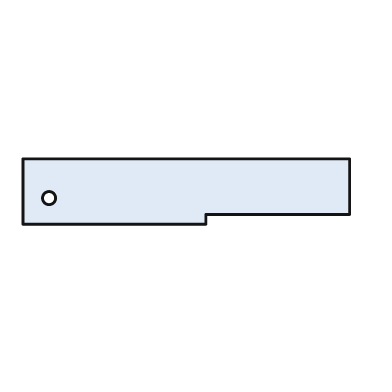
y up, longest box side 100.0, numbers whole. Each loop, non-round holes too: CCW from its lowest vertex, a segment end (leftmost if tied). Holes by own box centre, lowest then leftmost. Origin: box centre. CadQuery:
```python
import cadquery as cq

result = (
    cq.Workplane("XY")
    .moveTo(-50.0, -10.0)
    .lineTo(6.0, -10.0)
    .lineTo(6.0, -7.0)
    .lineTo(50.0, -7.0)
    .lineTo(50.0, 10.0)
    .lineTo(-50.0, 10.0)
    .close()
    .moveTo(-42.0, -2.0)
    .circle(2.0)
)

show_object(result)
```